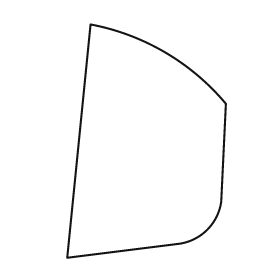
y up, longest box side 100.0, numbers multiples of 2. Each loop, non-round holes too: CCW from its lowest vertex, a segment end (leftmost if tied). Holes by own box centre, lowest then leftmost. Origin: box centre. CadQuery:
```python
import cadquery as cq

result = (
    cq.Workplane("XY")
    .moveTo(-34.0, -50.0)
    .lineTo(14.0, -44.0)
    .threePointArc((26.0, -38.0), (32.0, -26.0))
    .lineTo(34.0, 16.0)
    .threePointArc((8.0, 38.0), (-24.0, 50.0))
    .close()
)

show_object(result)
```